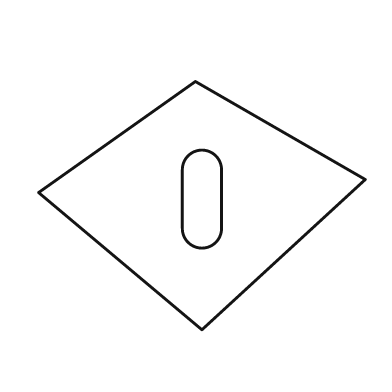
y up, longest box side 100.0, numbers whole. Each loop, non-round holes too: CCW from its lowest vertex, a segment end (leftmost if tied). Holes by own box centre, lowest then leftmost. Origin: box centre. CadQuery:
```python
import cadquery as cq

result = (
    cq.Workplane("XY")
    .moveTo(0.0, -38.0)
    .lineTo(50.0, 8.0)
    .lineTo(-2.0, 38.0)
    .lineTo(-50.0, 4.0)
    .close()
    .moveTo(-6.0, -7.0)
    .threePointArc((0.0, -13.0), (6.0, -7.0))
    .lineTo(6.0, 11.0)
    .threePointArc((0.0, 17.0), (-6.0, 11.0))
    .close()
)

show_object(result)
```